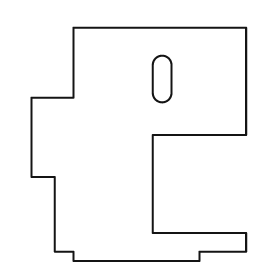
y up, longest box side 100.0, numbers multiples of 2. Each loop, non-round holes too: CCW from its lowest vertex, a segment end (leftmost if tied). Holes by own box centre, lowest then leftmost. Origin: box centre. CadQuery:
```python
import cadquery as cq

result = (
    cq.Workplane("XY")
    .moveTo(-28.0, -50.0)
    .lineTo(26.0, -50.0)
    .lineTo(26.0, -46.0)
    .lineTo(46.0, -46.0)
    .lineTo(46.0, -38.0)
    .lineTo(6.0, -38.0)
    .lineTo(6.0, 4.0)
    .lineTo(46.0, 4.0)
    .lineTo(46.0, 50.0)
    .lineTo(-28.0, 50.0)
    .lineTo(-28.0, 20.0)
    .lineTo(-46.0, 20.0)
    .lineTo(-46.0, -14.0)
    .lineTo(-36.0, -14.0)
    .lineTo(-36.0, -46.0)
    .lineTo(-28.0, -46.0)
    .close()
    .moveTo(6.0, 22.0)
    .threePointArc((10.0, 18.0), (14.0, 22.0))
    .lineTo(14.0, 34.0)
    .threePointArc((10.0, 38.0), (6.0, 34.0))
    .close()
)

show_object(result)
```